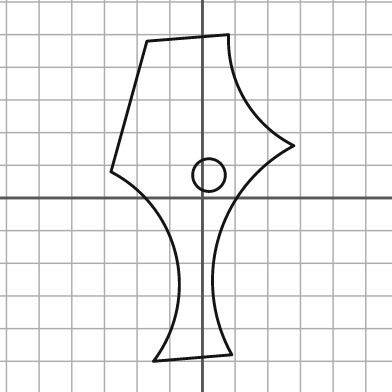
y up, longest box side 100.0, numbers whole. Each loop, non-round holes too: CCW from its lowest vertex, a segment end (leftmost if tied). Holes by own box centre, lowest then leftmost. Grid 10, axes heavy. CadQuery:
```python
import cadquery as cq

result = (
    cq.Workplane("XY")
    .moveTo(-15.0, -50.0)
    .lineTo(9.0, -48.0)
    .threePointArc((5.0, -12.0), (28.0, 16.0))
    .threePointArc((13.0, 30.0), (8.0, 50.0))
    .lineTo(-17.0, 48.0)
    .lineTo(-28.0, 8.0)
    .threePointArc((-8.0, -18.0), (-15.0, -50.0))
    .close()
    .moveTo(2.0, 7.0)
    .circle(5.0)
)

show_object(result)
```